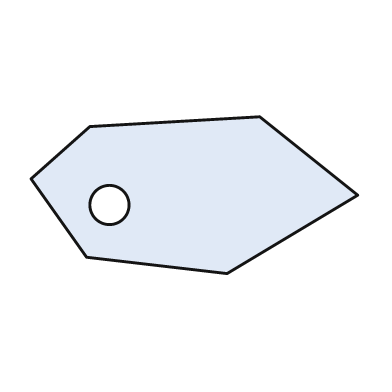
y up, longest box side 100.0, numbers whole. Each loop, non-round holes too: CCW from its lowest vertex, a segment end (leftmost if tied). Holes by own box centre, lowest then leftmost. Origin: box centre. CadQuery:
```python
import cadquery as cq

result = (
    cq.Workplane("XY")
    .moveTo(10.0, -24.0)
    .lineTo(50.0, 0.0)
    .lineTo(20.0, 24.0)
    .lineTo(-32.0, 21.0)
    .lineTo(-50.0, 5.0)
    .lineTo(-33.0, -19.0)
    .close()
    .moveTo(-26.0, -3.0)
    .circle(6.0)
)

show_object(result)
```